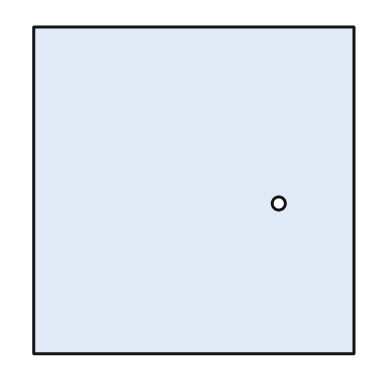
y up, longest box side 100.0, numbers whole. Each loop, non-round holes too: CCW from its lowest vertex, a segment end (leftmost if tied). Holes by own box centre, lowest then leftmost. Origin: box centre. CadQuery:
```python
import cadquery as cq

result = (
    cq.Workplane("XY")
    .moveTo(-49.0, -50.0)
    .lineTo(49.0, -50.0)
    .lineTo(49.0, 50.0)
    .lineTo(-49.0, 50.0)
    .close()
    .moveTo(26.0, -4.0)
    .circle(2.0)
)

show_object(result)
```